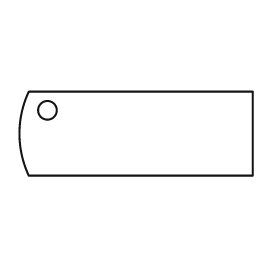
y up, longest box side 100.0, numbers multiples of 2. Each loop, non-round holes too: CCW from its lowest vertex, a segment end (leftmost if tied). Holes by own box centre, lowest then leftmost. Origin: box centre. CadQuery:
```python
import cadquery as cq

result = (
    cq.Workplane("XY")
    .moveTo(-46.0, -18.0)
    .lineTo(50.0, -18.0)
    .lineTo(50.0, 18.0)
    .lineTo(-46.0, 18.0)
    .threePointArc((-50.0, 0.0), (-46.0, -18.0))
    .close()
    .moveTo(-38.0, 10.0)
    .circle(4.0)
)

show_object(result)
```